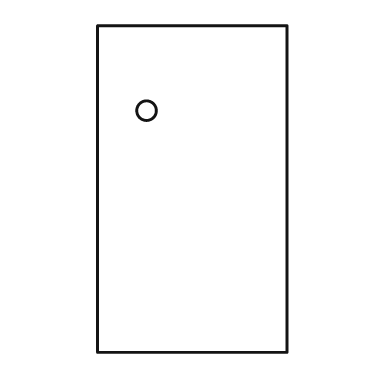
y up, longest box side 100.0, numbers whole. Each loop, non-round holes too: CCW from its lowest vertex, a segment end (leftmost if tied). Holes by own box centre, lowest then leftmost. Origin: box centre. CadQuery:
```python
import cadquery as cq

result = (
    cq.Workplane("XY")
    .moveTo(-29.0, -50.0)
    .lineTo(29.0, -50.0)
    .lineTo(29.0, 50.0)
    .lineTo(-29.0, 50.0)
    .close()
    .moveTo(-14.0, 24.0)
    .circle(3.0)
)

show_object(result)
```